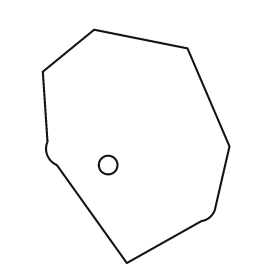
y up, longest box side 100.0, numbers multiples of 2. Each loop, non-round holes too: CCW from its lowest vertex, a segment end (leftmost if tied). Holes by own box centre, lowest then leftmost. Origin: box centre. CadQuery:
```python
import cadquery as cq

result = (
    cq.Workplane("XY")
    .moveTo(-4.0, -50.0)
    .lineTo(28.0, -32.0)
    .threePointArc((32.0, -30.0), (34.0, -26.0))
    .lineTo(40.0, 0.0)
    .lineTo(22.0, 42.0)
    .lineTo(-18.0, 50.0)
    .lineTo(-40.0, 32.0)
    .lineTo(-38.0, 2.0)
    .threePointArc((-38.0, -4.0), (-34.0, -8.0))
    .close()
    .moveTo(-12.0, -8.0)
    .circle(4.0)
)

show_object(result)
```